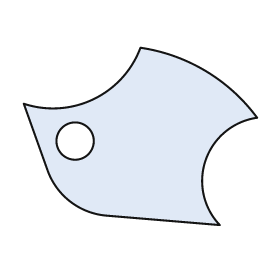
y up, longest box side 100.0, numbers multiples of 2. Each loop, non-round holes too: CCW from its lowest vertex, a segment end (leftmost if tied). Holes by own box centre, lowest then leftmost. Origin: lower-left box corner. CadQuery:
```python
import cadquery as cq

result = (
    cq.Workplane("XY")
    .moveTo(84.0, 0.0)
    .threePointArc((78.0, 28.0), (100.0, 46.0))
    .threePointArc((78.0, 66.0), (50.0, 76.0))
    .threePointArc((30.0, 54.0), (0.0, 52.0))
    .lineTo(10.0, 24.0)
    .threePointArc((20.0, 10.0), (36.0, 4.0))
    .close()
    .moveTo(22.0, 36.0)
    .circle(8.0)
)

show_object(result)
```